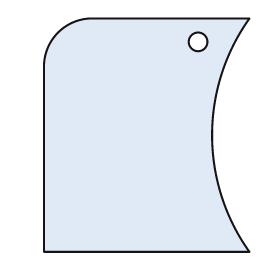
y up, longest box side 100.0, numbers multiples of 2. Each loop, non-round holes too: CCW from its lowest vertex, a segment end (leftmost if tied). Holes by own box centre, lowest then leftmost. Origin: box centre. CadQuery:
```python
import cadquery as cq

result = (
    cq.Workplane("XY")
    .moveTo(-44.0, -50.0)
    .lineTo(44.0, -50.0)
    .threePointArc((28.0, 0.0), (44.0, 50.0))
    .lineTo(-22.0, 50.0)
    .threePointArc((-38.0, 44.0), (-44.0, 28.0))
    .close()
    .moveTo(22.0, 40.0)
    .circle(4.0)
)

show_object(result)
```